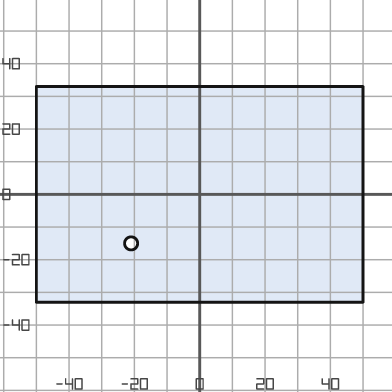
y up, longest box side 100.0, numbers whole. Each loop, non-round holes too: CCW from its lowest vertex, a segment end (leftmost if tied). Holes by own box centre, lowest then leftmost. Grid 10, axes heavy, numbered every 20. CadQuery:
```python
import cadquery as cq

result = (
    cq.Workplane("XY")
    .moveTo(-50.0, -33.0)
    .lineTo(50.0, -33.0)
    .lineTo(50.0, 33.0)
    .lineTo(-50.0, 33.0)
    .close()
    .moveTo(-21.0, -15.0)
    .circle(2.0)
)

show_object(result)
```